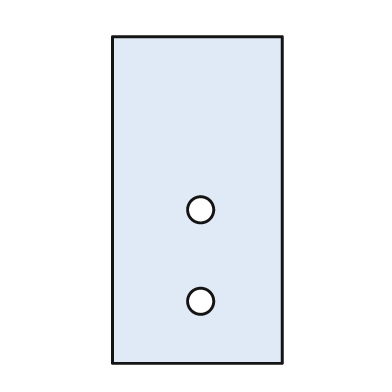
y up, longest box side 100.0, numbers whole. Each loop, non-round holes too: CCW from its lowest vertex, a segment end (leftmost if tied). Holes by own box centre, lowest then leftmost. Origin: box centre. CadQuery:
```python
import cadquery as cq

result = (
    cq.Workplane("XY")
    .moveTo(-26.0, -50.0)
    .lineTo(26.0, -50.0)
    .lineTo(26.0, 50.0)
    .lineTo(-26.0, 50.0)
    .close()
    .moveTo(1.0, -31.0)
    .circle(4.0)
    .moveTo(1.0, -3.0)
    .circle(4.0)
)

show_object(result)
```